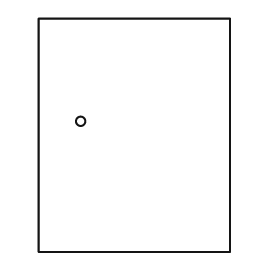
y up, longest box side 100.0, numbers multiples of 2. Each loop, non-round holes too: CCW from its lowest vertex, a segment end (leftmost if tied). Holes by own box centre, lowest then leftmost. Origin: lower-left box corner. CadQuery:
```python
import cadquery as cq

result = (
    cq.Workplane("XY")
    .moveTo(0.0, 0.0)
    .lineTo(82.0, 0.0)
    .lineTo(82.0, 100.0)
    .lineTo(0.0, 100.0)
    .close()
    .moveTo(18.0, 56.0)
    .circle(2.0)
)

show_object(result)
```